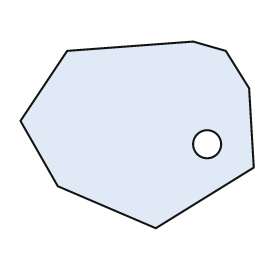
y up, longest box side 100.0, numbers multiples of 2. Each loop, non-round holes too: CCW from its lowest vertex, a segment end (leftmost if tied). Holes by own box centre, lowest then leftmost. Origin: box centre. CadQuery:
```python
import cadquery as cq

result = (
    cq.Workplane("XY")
    .moveTo(8.0, -40.0)
    .lineTo(50.0, -14.0)
    .lineTo(48.0, 20.0)
    .lineTo(38.0, 36.0)
    .lineTo(24.0, 40.0)
    .lineTo(-30.0, 36.0)
    .lineTo(-50.0, 6.0)
    .lineTo(-34.0, -22.0)
    .close()
    .moveTo(30.0, -4.0)
    .circle(6.0)
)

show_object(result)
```